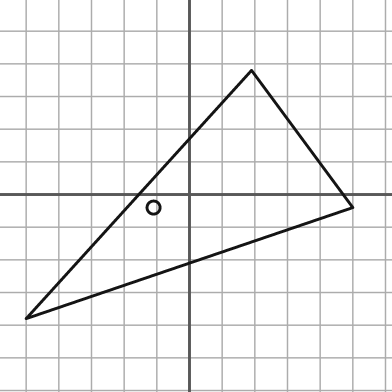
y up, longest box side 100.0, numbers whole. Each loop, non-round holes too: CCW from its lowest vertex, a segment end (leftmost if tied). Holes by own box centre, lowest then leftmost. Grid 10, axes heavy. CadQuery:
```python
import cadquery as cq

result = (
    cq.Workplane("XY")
    .moveTo(-50.0, -38.0)
    .lineTo(50.0, -4.0)
    .lineTo(19.0, 38.0)
    .close()
    .moveTo(-11.0, -4.0)
    .circle(2.0)
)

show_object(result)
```